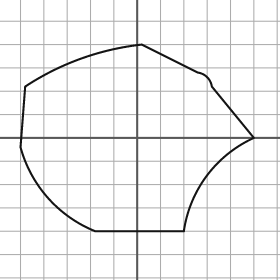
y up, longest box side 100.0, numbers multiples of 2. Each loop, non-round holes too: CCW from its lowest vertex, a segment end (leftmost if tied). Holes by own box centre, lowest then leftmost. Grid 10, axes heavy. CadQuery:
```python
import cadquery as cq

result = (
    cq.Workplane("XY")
    .moveTo(-18.0, -40.0)
    .lineTo(20.0, -40.0)
    .threePointArc((30.0, -16.0), (50.0, 0.0))
    .lineTo(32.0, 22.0)
    .threePointArc((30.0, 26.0), (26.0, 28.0))
    .lineTo(2.0, 40.0)
    .threePointArc((-24.0, 34.0), (-48.0, 22.0))
    .lineTo(-50.0, -4.0)
    .threePointArc((-38.0, -26.0), (-18.0, -40.0))
    .close()
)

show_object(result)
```